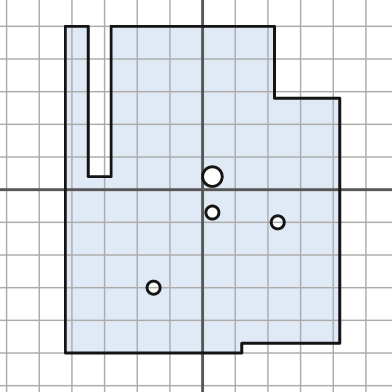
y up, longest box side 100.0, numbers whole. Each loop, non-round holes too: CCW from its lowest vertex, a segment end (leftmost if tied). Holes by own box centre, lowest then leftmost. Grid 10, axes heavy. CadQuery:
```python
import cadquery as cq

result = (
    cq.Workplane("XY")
    .moveTo(-42.0, -50.0)
    .lineTo(12.0, -50.0)
    .lineTo(12.0, -47.0)
    .lineTo(42.0, -47.0)
    .lineTo(42.0, 28.0)
    .lineTo(22.0, 28.0)
    .lineTo(22.0, 50.0)
    .lineTo(-28.0, 50.0)
    .lineTo(-28.0, 4.0)
    .lineTo(-35.0, 4.0)
    .lineTo(-35.0, 50.0)
    .lineTo(-42.0, 50.0)
    .close()
    .moveTo(-15.0, -30.0)
    .circle(2.0)
    .moveTo(23.0, -10.0)
    .circle(2.0)
    .moveTo(3.0, -7.0)
    .circle(2.0)
    .moveTo(3.0, 4.0)
    .circle(3.0)
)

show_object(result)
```